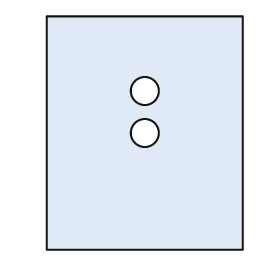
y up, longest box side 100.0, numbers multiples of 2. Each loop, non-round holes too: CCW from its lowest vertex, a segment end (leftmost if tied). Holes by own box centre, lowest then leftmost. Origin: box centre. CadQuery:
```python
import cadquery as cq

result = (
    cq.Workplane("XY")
    .moveTo(-42.0, -50.0)
    .lineTo(42.0, -50.0)
    .lineTo(42.0, 50.0)
    .lineTo(-42.0, 50.0)
    .close()
    .moveTo(0.0, 0.0)
    .circle(6.0)
    .moveTo(0.0, 18.0)
    .circle(6.0)
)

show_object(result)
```